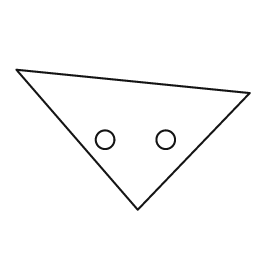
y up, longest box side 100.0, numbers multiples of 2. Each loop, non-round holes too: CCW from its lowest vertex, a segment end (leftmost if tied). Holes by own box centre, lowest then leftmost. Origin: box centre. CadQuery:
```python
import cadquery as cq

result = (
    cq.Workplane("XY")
    .moveTo(2.0, -30.0)
    .lineTo(50.0, 20.0)
    .lineTo(-50.0, 30.0)
    .close()
    .moveTo(-12.0, 0.0)
    .circle(4.0)
    .moveTo(14.0, 0.0)
    .circle(4.0)
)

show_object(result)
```